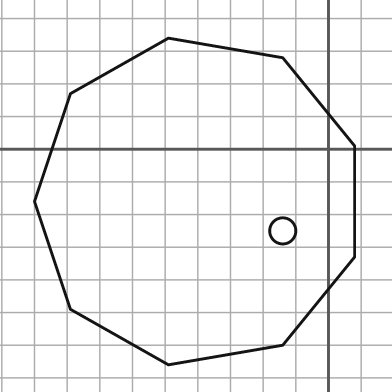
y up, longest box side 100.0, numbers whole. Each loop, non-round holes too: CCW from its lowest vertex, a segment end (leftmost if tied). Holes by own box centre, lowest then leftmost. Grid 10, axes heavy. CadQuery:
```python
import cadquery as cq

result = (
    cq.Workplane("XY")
    .moveTo(-49.0, -66.0)
    .lineTo(-14.0, -60.0)
    .lineTo(8.0, -33.0)
    .lineTo(8.0, 1.0)
    .lineTo(-14.0, 28.0)
    .lineTo(-49.0, 34.0)
    .lineTo(-79.0, 17.0)
    .lineTo(-90.0, -16.0)
    .lineTo(-79.0, -49.0)
    .close()
    .moveTo(-14.0, -25.0)
    .circle(4.0)
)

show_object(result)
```